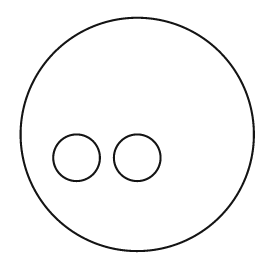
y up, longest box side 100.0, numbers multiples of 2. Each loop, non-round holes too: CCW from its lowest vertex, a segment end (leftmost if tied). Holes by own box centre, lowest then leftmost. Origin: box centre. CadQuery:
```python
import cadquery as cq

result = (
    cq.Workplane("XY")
    .moveTo(0.0, 0.0)
    .circle(50.0)
    .moveTo(-26.0, -10.0)
    .circle(10.0)
    .moveTo(0.0, -10.0)
    .circle(10.0)
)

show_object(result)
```